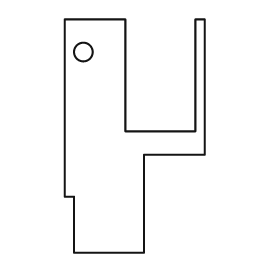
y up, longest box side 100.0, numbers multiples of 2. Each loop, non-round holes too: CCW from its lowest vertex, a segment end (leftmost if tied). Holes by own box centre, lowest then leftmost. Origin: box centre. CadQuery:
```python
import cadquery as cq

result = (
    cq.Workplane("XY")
    .moveTo(-26.0, -50.0)
    .lineTo(4.0, -50.0)
    .lineTo(4.0, -8.0)
    .lineTo(30.0, -8.0)
    .lineTo(30.0, 50.0)
    .lineTo(26.0, 50.0)
    .lineTo(26.0, 2.0)
    .lineTo(-4.0, 2.0)
    .lineTo(-4.0, 50.0)
    .lineTo(-30.0, 50.0)
    .lineTo(-30.0, -26.0)
    .lineTo(-26.0, -26.0)
    .close()
    .moveTo(-22.0, 36.0)
    .circle(4.0)
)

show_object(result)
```